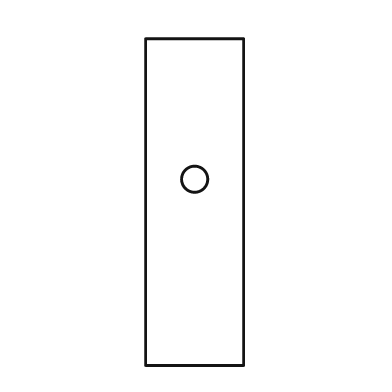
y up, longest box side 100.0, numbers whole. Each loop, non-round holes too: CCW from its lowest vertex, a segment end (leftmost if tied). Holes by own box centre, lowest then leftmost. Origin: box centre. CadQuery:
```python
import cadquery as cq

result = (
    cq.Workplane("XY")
    .moveTo(-15.0, -50.0)
    .lineTo(15.0, -50.0)
    .lineTo(15.0, 50.0)
    .lineTo(-15.0, 50.0)
    .close()
    .moveTo(0.0, 7.0)
    .circle(4.0)
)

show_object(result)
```